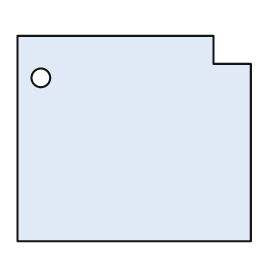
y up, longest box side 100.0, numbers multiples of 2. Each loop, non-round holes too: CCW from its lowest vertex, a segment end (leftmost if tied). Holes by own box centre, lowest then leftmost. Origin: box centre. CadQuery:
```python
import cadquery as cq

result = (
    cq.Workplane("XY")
    .moveTo(-50.0, -44.0)
    .lineTo(50.0, -44.0)
    .lineTo(50.0, 32.0)
    .lineTo(34.0, 32.0)
    .lineTo(34.0, 44.0)
    .lineTo(-50.0, 44.0)
    .close()
    .moveTo(-40.0, 26.0)
    .circle(4.0)
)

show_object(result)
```